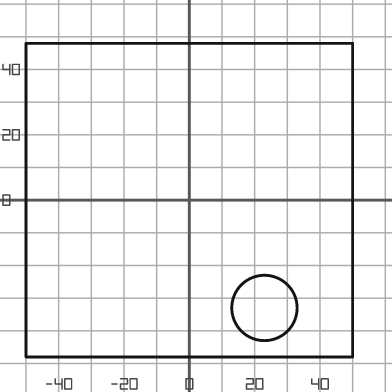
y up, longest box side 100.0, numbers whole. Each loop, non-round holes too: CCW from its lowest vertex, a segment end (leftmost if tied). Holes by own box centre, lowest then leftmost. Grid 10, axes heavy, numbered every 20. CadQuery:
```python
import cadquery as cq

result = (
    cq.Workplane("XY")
    .moveTo(-50.0, -48.0)
    .lineTo(50.0, -48.0)
    .lineTo(50.0, 48.0)
    .lineTo(-50.0, 48.0)
    .close()
    .moveTo(23.0, -33.0)
    .circle(10.0)
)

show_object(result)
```